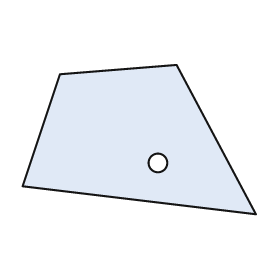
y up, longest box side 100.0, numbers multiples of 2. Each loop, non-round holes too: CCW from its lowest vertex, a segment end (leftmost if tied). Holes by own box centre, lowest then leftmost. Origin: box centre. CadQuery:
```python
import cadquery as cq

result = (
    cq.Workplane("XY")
    .moveTo(50.0, -32.0)
    .lineTo(16.0, 32.0)
    .lineTo(-34.0, 28.0)
    .lineTo(-50.0, -20.0)
    .close()
    .moveTo(8.0, -10.0)
    .circle(4.0)
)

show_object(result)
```